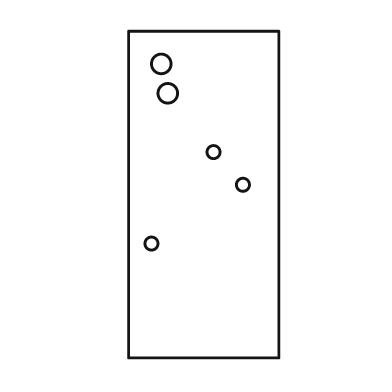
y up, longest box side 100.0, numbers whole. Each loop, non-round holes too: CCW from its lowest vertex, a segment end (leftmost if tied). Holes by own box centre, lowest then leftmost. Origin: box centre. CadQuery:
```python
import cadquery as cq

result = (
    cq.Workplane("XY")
    .moveTo(-23.0, -50.0)
    .lineTo(23.0, -50.0)
    .lineTo(23.0, 50.0)
    .lineTo(-23.0, 50.0)
    .close()
    .moveTo(-16.0, -15.0)
    .circle(2.0)
    .moveTo(12.0, 3.0)
    .circle(2.0)
    .moveTo(3.0, 13.0)
    .circle(2.0)
    .moveTo(-11.0, 31.0)
    .circle(3.0)
    .moveTo(-13.0, 40.0)
    .circle(3.0)
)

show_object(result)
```